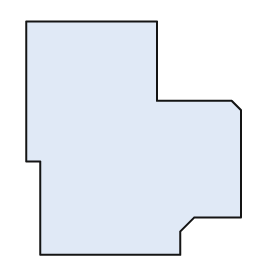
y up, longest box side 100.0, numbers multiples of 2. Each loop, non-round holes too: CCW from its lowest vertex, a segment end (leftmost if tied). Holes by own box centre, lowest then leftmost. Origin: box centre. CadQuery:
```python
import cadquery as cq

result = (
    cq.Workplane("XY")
    .moveTo(-40.0, -50.0)
    .lineTo(20.0, -50.0)
    .lineTo(20.0, -40.0)
    .lineTo(26.0, -34.0)
    .lineTo(46.0, -34.0)
    .lineTo(46.0, 12.0)
    .lineTo(42.0, 16.0)
    .lineTo(10.0, 16.0)
    .lineTo(10.0, 50.0)
    .lineTo(-46.0, 50.0)
    .lineTo(-46.0, -10.0)
    .lineTo(-40.0, -10.0)
    .close()
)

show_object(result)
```